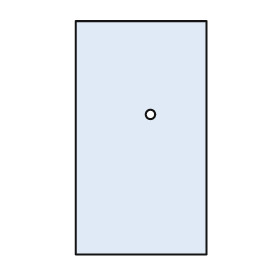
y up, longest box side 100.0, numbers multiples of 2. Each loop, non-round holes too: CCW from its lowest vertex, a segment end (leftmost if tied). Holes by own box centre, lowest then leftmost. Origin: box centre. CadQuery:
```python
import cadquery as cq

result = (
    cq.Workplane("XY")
    .moveTo(-28.0, -50.0)
    .lineTo(28.0, -50.0)
    .lineTo(28.0, 50.0)
    .lineTo(-28.0, 50.0)
    .close()
    .moveTo(4.0, 10.0)
    .circle(2.0)
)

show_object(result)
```